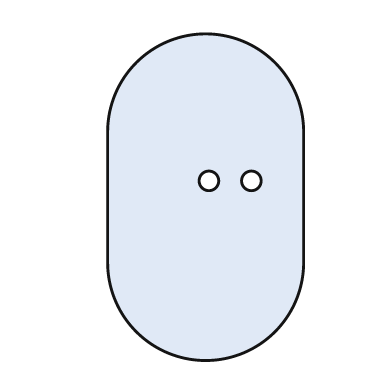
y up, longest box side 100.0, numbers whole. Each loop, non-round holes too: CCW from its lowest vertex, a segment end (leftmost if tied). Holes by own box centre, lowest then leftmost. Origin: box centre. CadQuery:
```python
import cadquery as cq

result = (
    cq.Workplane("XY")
    .moveTo(-30.0, -20.0)
    .threePointArc((0.0, -50.0), (30.0, -20.0))
    .lineTo(30.0, 20.0)
    .threePointArc((0.0, 50.0), (-30.0, 20.0))
    .close()
    .moveTo(1.0, 5.0)
    .circle(3.0)
    .moveTo(14.0, 5.0)
    .circle(3.0)
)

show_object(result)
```